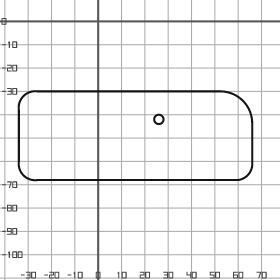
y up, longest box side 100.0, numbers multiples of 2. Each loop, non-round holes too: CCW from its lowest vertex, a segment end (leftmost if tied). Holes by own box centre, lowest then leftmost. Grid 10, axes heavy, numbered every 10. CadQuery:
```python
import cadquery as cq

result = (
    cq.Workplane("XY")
    .moveTo(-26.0, -68.0)
    .lineTo(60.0, -68.0)
    .threePointArc((64.0, -66.0), (66.0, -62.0))
    .lineTo(66.0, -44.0)
    .threePointArc((62.0, -34.0), (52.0, -30.0))
    .lineTo(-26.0, -30.0)
    .threePointArc((-32.0, -32.0), (-34.0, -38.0))
    .lineTo(-34.0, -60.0)
    .threePointArc((-32.0, -66.0), (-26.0, -68.0))
    .close()
    .moveTo(26.0, -42.0)
    .circle(2.0)
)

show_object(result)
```